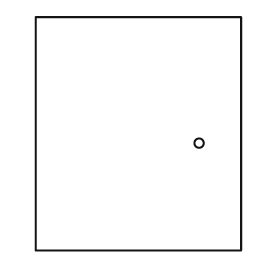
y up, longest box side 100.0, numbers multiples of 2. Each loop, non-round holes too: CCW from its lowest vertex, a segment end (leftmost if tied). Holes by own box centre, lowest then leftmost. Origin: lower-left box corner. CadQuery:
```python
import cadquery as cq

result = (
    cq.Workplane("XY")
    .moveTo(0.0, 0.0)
    .lineTo(88.0, 0.0)
    .lineTo(88.0, 100.0)
    .lineTo(0.0, 100.0)
    .close()
    .moveTo(70.0, 46.0)
    .circle(2.0)
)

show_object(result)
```